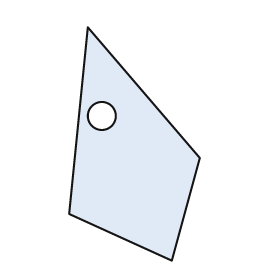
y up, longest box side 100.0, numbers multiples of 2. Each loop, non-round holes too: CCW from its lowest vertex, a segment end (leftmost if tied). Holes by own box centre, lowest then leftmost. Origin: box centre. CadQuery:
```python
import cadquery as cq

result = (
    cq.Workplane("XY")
    .moveTo(16.0, -50.0)
    .lineTo(28.0, -6.0)
    .lineTo(-20.0, 50.0)
    .lineTo(-28.0, -30.0)
    .close()
    .moveTo(-14.0, 12.0)
    .circle(6.0)
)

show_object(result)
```